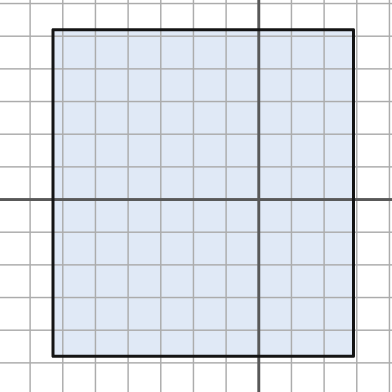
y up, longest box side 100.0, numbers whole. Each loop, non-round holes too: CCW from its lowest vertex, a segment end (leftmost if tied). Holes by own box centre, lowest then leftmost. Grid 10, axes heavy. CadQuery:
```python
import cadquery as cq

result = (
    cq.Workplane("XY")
    .moveTo(-63.0, -48.0)
    .lineTo(29.0, -48.0)
    .lineTo(29.0, 52.0)
    .lineTo(-63.0, 52.0)
    .close()
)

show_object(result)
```